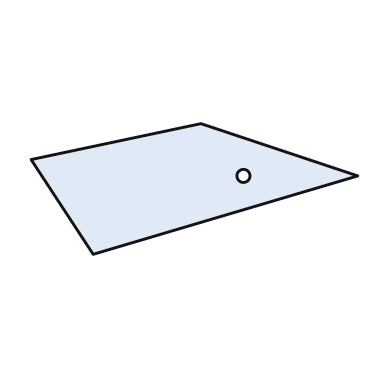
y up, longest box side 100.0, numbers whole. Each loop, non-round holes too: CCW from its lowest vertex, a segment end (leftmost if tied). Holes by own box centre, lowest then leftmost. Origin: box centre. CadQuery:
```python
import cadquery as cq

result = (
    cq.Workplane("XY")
    .moveTo(-31.0, -20.0)
    .lineTo(50.0, 4.0)
    .lineTo(2.0, 20.0)
    .lineTo(-50.0, 9.0)
    .close()
    .moveTo(15.0, 4.0)
    .circle(2.0)
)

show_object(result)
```